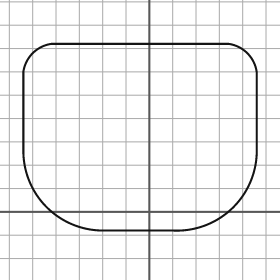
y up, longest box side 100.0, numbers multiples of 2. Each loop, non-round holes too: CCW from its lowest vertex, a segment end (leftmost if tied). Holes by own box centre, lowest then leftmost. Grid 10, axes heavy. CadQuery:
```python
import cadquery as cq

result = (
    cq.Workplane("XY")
    .moveTo(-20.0, -8.0)
    .lineTo(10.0, -8.0)
    .threePointArc((36.0, 2.0), (46.0, 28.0))
    .lineTo(46.0, 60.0)
    .threePointArc((42.0, 68.0), (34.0, 72.0))
    .lineTo(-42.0, 72.0)
    .threePointArc((-50.0, 68.0), (-54.0, 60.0))
    .lineTo(-54.0, 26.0)
    .threePointArc((-44.0, 2.0), (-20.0, -8.0))
    .close()
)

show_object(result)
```